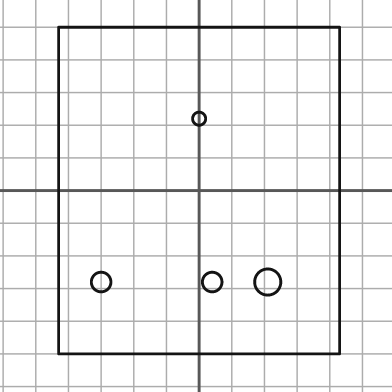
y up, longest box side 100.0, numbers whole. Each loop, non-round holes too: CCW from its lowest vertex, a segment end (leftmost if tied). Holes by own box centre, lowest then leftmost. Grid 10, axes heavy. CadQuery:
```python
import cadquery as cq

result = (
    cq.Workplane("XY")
    .moveTo(-43.0, -50.0)
    .lineTo(43.0, -50.0)
    .lineTo(43.0, 50.0)
    .lineTo(-43.0, 50.0)
    .close()
    .moveTo(-30.0, -28.0)
    .circle(3.0)
    .moveTo(4.0, -28.0)
    .circle(3.0)
    .moveTo(21.0, -28.0)
    .circle(4.0)
    .moveTo(0.0, 22.0)
    .circle(2.0)
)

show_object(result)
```